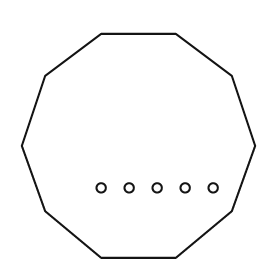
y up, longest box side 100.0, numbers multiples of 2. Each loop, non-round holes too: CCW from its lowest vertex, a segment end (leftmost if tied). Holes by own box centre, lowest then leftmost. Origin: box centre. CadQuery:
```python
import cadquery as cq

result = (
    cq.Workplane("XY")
    .moveTo(-16.0, -48.0)
    .lineTo(16.0, -48.0)
    .lineTo(40.0, -28.0)
    .lineTo(50.0, 0.0)
    .lineTo(40.0, 30.0)
    .lineTo(16.0, 48.0)
    .lineTo(-16.0, 48.0)
    .lineTo(-40.0, 30.0)
    .lineTo(-50.0, 0.0)
    .lineTo(-40.0, -28.0)
    .close()
    .moveTo(-16.0, -18.0)
    .circle(2.0)
    .moveTo(-4.0, -18.0)
    .circle(2.0)
    .moveTo(8.0, -18.0)
    .circle(2.0)
    .moveTo(20.0, -18.0)
    .circle(2.0)
    .moveTo(32.0, -18.0)
    .circle(2.0)
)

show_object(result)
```